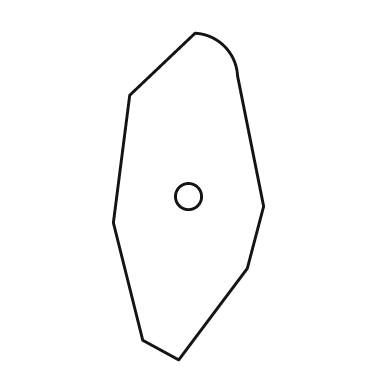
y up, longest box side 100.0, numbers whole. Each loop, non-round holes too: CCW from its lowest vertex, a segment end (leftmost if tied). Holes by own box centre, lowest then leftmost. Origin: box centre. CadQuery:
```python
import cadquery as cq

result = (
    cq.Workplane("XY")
    .moveTo(-3.0, -50.0)
    .lineTo(18.0, -22.0)
    .lineTo(23.0, -3.0)
    .lineTo(15.0, 37.0)
    .threePointArc((11.0, 46.0), (2.0, 50.0))
    .lineTo(-18.0, 31.0)
    .lineTo(-23.0, -8.0)
    .lineTo(-14.0, -44.0)
    .close()
    .moveTo(0.0, 0.0)
    .circle(4.0)
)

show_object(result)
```